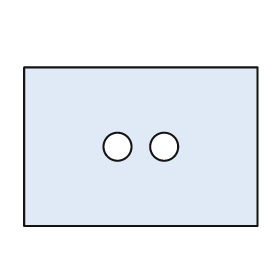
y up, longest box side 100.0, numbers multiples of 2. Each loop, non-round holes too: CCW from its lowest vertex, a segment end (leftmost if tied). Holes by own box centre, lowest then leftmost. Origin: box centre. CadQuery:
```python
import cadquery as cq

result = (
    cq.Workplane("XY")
    .moveTo(-50.0, -34.0)
    .lineTo(50.0, -34.0)
    .lineTo(50.0, 34.0)
    .lineTo(-50.0, 34.0)
    .close()
    .moveTo(-10.0, 0.0)
    .circle(6.0)
    .moveTo(10.0, 0.0)
    .circle(6.0)
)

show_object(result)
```